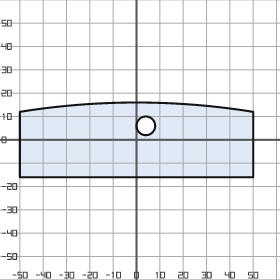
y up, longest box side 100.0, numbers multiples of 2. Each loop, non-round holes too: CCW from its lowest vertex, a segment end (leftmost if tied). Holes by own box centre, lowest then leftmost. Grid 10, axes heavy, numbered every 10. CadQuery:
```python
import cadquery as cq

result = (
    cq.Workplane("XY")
    .moveTo(-50.0, -16.0)
    .lineTo(50.0, -16.0)
    .lineTo(50.0, 12.0)
    .threePointArc((0.0, 16.0), (-50.0, 12.0))
    .close()
    .moveTo(4.0, 6.0)
    .circle(4.0)
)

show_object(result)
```